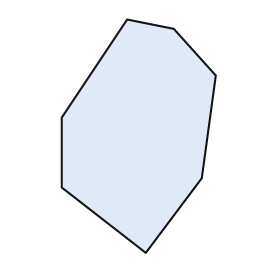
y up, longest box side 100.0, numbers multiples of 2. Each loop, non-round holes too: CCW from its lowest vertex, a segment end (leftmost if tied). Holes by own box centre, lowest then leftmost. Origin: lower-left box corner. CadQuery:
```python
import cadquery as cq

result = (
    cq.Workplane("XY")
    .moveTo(36.0, 0.0)
    .lineTo(60.0, 32.0)
    .lineTo(66.0, 76.0)
    .lineTo(48.0, 96.0)
    .lineTo(28.0, 100.0)
    .lineTo(0.0, 58.0)
    .lineTo(0.0, 28.0)
    .close()
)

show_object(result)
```